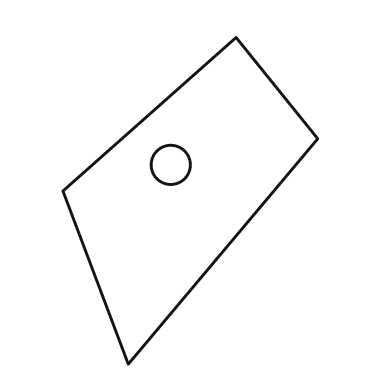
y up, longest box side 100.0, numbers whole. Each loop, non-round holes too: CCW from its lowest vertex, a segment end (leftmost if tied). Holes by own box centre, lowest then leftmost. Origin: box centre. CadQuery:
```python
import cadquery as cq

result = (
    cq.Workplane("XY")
    .moveTo(-19.0, -50.0)
    .lineTo(39.0, 19.0)
    .lineTo(14.0, 50.0)
    .lineTo(-39.0, 3.0)
    .close()
    .moveTo(-6.0, 11.0)
    .circle(6.0)
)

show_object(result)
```